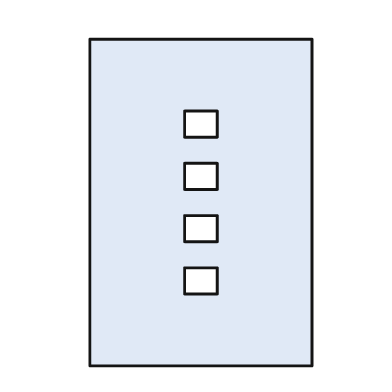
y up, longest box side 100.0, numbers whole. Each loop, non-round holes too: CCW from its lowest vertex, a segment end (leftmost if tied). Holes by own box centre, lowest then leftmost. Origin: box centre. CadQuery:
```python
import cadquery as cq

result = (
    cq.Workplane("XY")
    .moveTo(-34.0, -50.0)
    .lineTo(34.0, -50.0)
    .lineTo(34.0, 50.0)
    .lineTo(-34.0, 50.0)
    .close()
    .moveTo(-5.0, -28.0)
    .lineTo(5.0, -28.0)
    .lineTo(5.0, -20.0)
    .lineTo(-5.0, -20.0)
    .close()
    .moveTo(-5.0, -12.0)
    .lineTo(5.0, -12.0)
    .lineTo(5.0, -4.0)
    .lineTo(-5.0, -4.0)
    .close()
    .moveTo(-5.0, 4.0)
    .lineTo(5.0, 4.0)
    .lineTo(5.0, 12.0)
    .lineTo(-5.0, 12.0)
    .close()
    .moveTo(-5.0, 20.0)
    .lineTo(5.0, 20.0)
    .lineTo(5.0, 28.0)
    .lineTo(-5.0, 28.0)
    .close()
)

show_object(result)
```